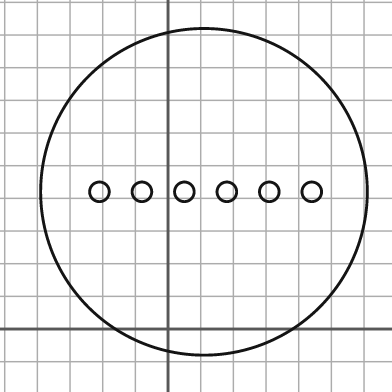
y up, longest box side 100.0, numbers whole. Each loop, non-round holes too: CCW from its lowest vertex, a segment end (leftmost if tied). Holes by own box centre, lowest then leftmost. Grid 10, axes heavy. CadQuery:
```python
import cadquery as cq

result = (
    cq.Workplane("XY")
    .moveTo(11.0, 42.0)
    .circle(50.0)
    .moveTo(-21.0, 42.0)
    .circle(3.0)
    .moveTo(-8.0, 42.0)
    .circle(3.0)
    .moveTo(5.0, 42.0)
    .circle(3.0)
    .moveTo(18.0, 42.0)
    .circle(3.0)
    .moveTo(31.0, 42.0)
    .circle(3.0)
    .moveTo(44.0, 42.0)
    .circle(3.0)
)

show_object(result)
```